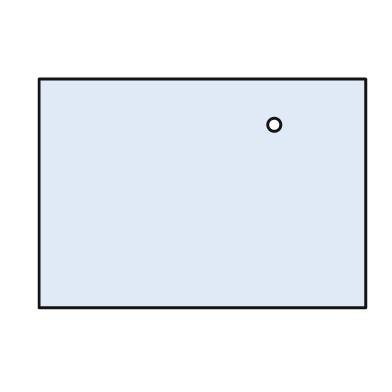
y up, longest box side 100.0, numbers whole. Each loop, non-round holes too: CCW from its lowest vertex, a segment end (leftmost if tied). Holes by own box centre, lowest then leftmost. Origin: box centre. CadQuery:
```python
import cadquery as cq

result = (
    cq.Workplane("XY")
    .moveTo(-50.0, -35.0)
    .lineTo(50.0, -35.0)
    .lineTo(50.0, 35.0)
    .lineTo(-50.0, 35.0)
    .close()
    .moveTo(22.0, 21.0)
    .circle(2.0)
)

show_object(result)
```